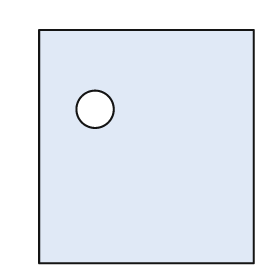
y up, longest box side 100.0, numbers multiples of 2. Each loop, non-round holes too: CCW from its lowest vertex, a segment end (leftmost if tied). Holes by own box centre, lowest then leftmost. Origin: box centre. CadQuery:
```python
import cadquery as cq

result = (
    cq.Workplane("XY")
    .moveTo(-46.0, -50.0)
    .lineTo(46.0, -50.0)
    .lineTo(46.0, 50.0)
    .lineTo(-46.0, 50.0)
    .close()
    .moveTo(-22.0, 16.0)
    .circle(8.0)
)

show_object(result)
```